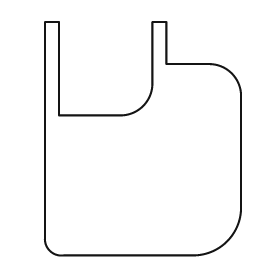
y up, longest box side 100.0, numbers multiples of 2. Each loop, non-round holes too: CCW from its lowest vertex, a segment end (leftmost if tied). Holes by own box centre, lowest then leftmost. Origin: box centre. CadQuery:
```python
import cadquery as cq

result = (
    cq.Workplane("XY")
    .moveTo(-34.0, -50.0)
    .lineTo(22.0, -50.0)
    .threePointArc((36.0, -44.0), (42.0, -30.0))
    .lineTo(42.0, 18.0)
    .threePointArc((38.0, 28.0), (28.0, 32.0))
    .lineTo(10.0, 32.0)
    .lineTo(10.0, 50.0)
    .lineTo(4.0, 50.0)
    .lineTo(4.0, 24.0)
    .threePointArc((0.0, 14.0), (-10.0, 10.0))
    .lineTo(-36.0, 10.0)
    .lineTo(-36.0, 50.0)
    .lineTo(-42.0, 50.0)
    .lineTo(-42.0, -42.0)
    .threePointArc((-40.0, -48.0), (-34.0, -50.0))
    .close()
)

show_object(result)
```